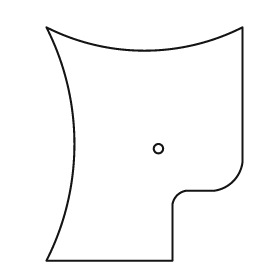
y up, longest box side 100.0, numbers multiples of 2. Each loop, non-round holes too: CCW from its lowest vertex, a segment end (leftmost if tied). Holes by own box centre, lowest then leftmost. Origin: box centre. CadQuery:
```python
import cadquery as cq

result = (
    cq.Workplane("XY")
    .moveTo(-42.0, -50.0)
    .lineTo(12.0, -50.0)
    .lineTo(12.0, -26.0)
    .threePointArc((14.0, -22.0), (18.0, -20.0))
    .lineTo(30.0, -20.0)
    .threePointArc((38.0, -16.0), (42.0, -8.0))
    .lineTo(42.0, 50.0)
    .threePointArc((0.0, 40.0), (-42.0, 50.0))
    .threePointArc((-30.0, 0.0), (-42.0, -50.0))
    .close()
    .moveTo(6.0, -2.0)
    .circle(2.0)
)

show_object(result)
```